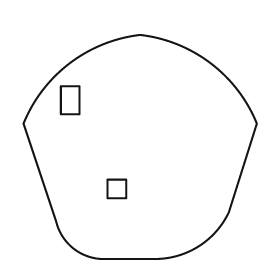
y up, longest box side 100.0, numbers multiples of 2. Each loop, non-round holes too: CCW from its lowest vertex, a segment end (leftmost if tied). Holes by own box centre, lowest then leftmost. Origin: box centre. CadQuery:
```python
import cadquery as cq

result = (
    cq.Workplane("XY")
    .moveTo(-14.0, -48.0)
    .lineTo(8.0, -48.0)
    .threePointArc((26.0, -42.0), (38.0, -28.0))
    .lineTo(50.0, 10.0)
    .threePointArc((30.0, 36.0), (0.0, 48.0))
    .threePointArc((-30.0, 36.0), (-50.0, 10.0))
    .lineTo(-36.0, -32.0)
    .threePointArc((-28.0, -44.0), (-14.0, -48.0))
    .close()
    .moveTo(-14.0, -22.0)
    .lineTo(-6.0, -22.0)
    .lineTo(-6.0, -14.0)
    .lineTo(-14.0, -14.0)
    .close()
    .moveTo(-34.0, 14.0)
    .lineTo(-26.0, 14.0)
    .lineTo(-26.0, 26.0)
    .lineTo(-34.0, 26.0)
    .close()
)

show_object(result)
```